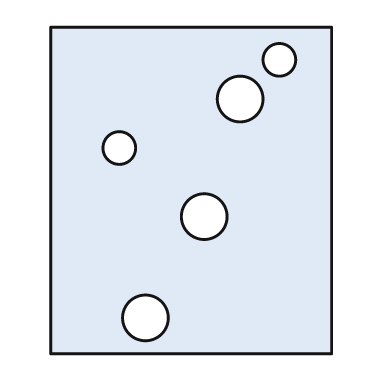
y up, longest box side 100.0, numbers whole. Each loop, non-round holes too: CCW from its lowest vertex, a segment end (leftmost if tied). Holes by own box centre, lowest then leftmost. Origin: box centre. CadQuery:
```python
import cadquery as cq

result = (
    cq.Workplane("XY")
    .moveTo(-43.0, -50.0)
    .lineTo(43.0, -50.0)
    .lineTo(43.0, 50.0)
    .lineTo(-43.0, 50.0)
    .close()
    .moveTo(-14.0, -39.0)
    .circle(7.0)
    .moveTo(4.0, -8.0)
    .circle(7.0)
    .moveTo(-22.0, 13.0)
    .circle(5.0)
    .moveTo(15.0, 28.0)
    .circle(7.0)
    .moveTo(27.0, 40.0)
    .circle(5.0)
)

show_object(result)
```